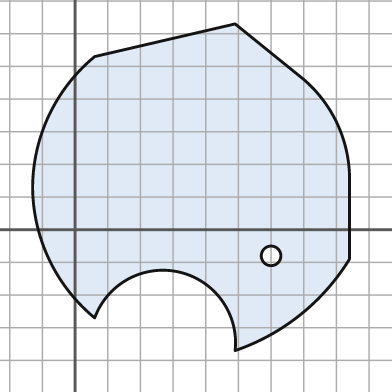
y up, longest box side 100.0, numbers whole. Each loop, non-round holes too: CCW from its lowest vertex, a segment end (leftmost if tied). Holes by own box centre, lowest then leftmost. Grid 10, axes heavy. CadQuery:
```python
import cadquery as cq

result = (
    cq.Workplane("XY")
    .moveTo(49.0, -37.0)
    .threePointArc((69.0, -26.0), (84.0, -9.0))
    .lineTo(84.0, 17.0)
    .threePointArc((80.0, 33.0), (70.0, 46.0))
    .lineTo(49.0, 63.0)
    .lineTo(6.0, 53.0)
    .threePointArc((-8.0, 35.0), (-13.0, 13.0))
    .threePointArc((-8.0, -9.0), (6.0, -27.0))
    .threePointArc((32.0, -13.0), (49.0, -37.0))
    .close()
    .moveTo(60.0, -8.0)
    .circle(3.0)
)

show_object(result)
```